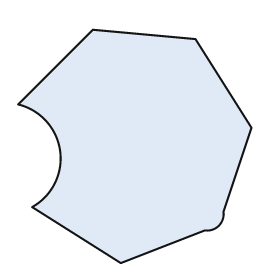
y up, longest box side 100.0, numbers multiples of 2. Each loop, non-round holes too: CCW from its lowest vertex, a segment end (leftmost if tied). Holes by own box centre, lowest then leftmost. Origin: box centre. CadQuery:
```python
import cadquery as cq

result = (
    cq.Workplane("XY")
    .moveTo(-6.0, -50.0)
    .lineTo(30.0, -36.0)
    .threePointArc((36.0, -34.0), (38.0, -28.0))
    .lineTo(50.0, 8.0)
    .lineTo(26.0, 46.0)
    .lineTo(-18.0, 50.0)
    .lineTo(-50.0, 18.0)
    .threePointArc((-32.0, -2.0), (-44.0, -26.0))
    .close()
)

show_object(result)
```